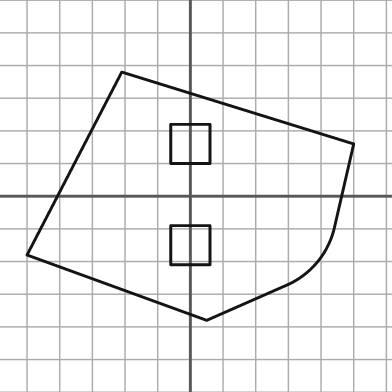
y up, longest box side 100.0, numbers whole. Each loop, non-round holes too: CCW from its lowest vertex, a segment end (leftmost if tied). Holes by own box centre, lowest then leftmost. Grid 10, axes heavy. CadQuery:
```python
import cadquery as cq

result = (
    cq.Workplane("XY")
    .moveTo(5.0, -38.0)
    .lineTo(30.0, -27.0)
    .threePointArc((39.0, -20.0), (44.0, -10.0))
    .lineTo(50.0, 16.0)
    .lineTo(-21.0, 38.0)
    .lineTo(-50.0, -18.0)
    .close()
    .moveTo(-6.0, -21.0)
    .lineTo(6.0, -21.0)
    .lineTo(6.0, -9.0)
    .lineTo(-6.0, -9.0)
    .close()
    .moveTo(-6.0, 10.0)
    .lineTo(6.0, 10.0)
    .lineTo(6.0, 22.0)
    .lineTo(-6.0, 22.0)
    .close()
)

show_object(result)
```